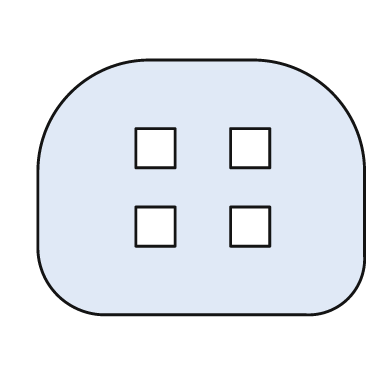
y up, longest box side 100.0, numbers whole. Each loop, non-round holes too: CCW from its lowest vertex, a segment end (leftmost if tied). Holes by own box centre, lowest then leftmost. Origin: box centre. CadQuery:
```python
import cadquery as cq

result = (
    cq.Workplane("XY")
    .moveTo(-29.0, -39.0)
    .lineTo(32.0, -39.0)
    .threePointArc((45.0, -34.0), (50.0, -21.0))
    .lineTo(50.0, 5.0)
    .threePointArc((40.0, 29.0), (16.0, 39.0))
    .lineTo(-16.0, 39.0)
    .threePointArc((-40.0, 29.0), (-50.0, 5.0))
    .lineTo(-50.0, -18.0)
    .threePointArc((-44.0, -33.0), (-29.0, -39.0))
    .close()
    .moveTo(-20.0, -18.0)
    .lineTo(-8.0, -18.0)
    .lineTo(-8.0, -6.0)
    .lineTo(-20.0, -6.0)
    .close()
    .moveTo(9.0, -18.0)
    .lineTo(21.0, -18.0)
    .lineTo(21.0, -6.0)
    .lineTo(9.0, -6.0)
    .close()
    .moveTo(-20.0, 6.0)
    .lineTo(-8.0, 6.0)
    .lineTo(-8.0, 18.0)
    .lineTo(-20.0, 18.0)
    .close()
    .moveTo(9.0, 6.0)
    .lineTo(21.0, 6.0)
    .lineTo(21.0, 18.0)
    .lineTo(9.0, 18.0)
    .close()
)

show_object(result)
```